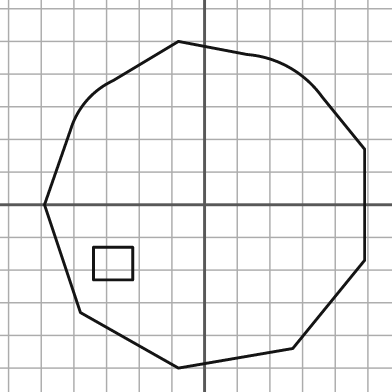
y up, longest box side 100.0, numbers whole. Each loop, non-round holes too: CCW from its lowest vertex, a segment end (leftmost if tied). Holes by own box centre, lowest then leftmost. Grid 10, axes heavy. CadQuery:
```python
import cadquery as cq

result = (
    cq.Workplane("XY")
    .moveTo(-8.0, -50.0)
    .lineTo(27.0, -44.0)
    .lineTo(49.0, -17.0)
    .lineTo(49.0, 17.0)
    .lineTo(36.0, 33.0)
    .threePointArc((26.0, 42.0), (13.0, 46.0))
    .lineTo(-8.0, 50.0)
    .lineTo(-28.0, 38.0)
    .threePointArc((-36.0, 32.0), (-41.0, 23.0))
    .lineTo(-49.0, 0.0)
    .lineTo(-38.0, -33.0)
    .close()
    .moveTo(-34.0, -23.0)
    .lineTo(-22.0, -23.0)
    .lineTo(-22.0, -13.0)
    .lineTo(-34.0, -13.0)
    .close()
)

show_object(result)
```